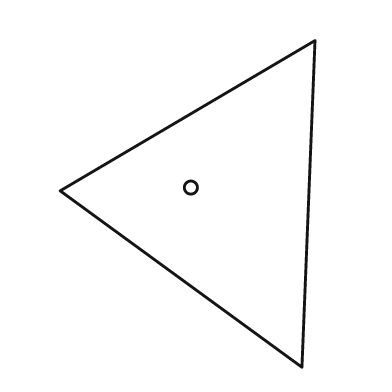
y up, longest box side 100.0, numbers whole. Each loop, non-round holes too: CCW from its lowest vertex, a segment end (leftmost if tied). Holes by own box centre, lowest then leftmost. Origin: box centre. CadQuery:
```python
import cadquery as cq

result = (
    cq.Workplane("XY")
    .moveTo(35.0, -50.0)
    .lineTo(39.0, 50.0)
    .lineTo(-39.0, 4.0)
    .close()
    .moveTo(1.0, 5.0)
    .circle(2.0)
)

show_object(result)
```